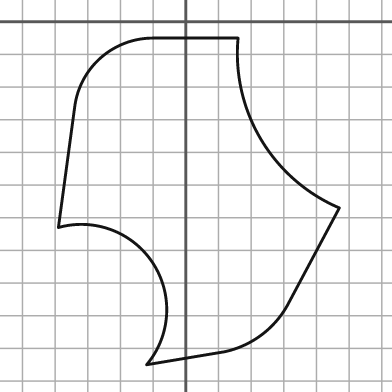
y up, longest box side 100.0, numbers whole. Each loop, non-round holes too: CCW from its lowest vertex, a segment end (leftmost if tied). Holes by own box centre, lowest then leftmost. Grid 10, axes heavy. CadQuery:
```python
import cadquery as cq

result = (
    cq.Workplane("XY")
    .moveTo(-12.0, -105.0)
    .lineTo(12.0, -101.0)
    .threePointArc((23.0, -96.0), (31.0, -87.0))
    .lineTo(47.0, -57.0)
    .threePointArc((23.0, -36.0), (16.0, -5.0))
    .lineTo(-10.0, -5.0)
    .threePointArc((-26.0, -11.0), (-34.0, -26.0))
    .lineTo(-39.0, -63.0)
    .threePointArc((-10.0, -74.0), (-12.0, -105.0))
    .close()
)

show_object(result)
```